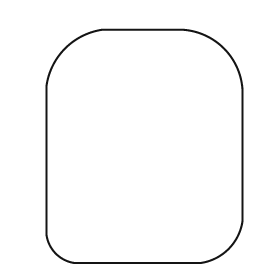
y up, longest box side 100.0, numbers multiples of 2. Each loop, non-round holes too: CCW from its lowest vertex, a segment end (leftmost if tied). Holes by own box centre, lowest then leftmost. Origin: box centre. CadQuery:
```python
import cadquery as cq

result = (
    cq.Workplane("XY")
    .moveTo(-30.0, -50.0)
    .lineTo(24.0, -50.0)
    .threePointArc((36.0, -44.0), (42.0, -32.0))
    .lineTo(42.0, 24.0)
    .threePointArc((34.0, 42.0), (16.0, 50.0))
    .lineTo(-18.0, 50.0)
    .threePointArc((-34.0, 42.0), (-42.0, 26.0))
    .lineTo(-42.0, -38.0)
    .threePointArc((-38.0, -46.0), (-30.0, -50.0))
    .close()
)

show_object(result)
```